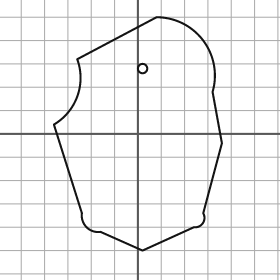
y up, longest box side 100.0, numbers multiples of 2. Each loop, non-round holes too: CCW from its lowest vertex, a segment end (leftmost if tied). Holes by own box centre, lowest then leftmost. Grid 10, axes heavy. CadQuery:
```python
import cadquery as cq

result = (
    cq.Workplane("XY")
    .moveTo(2.0, -50.0)
    .lineTo(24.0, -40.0)
    .threePointArc((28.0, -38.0), (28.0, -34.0))
    .lineTo(36.0, -4.0)
    .lineTo(32.0, 18.0)
    .threePointArc((28.0, 40.0), (8.0, 50.0))
    .lineTo(-26.0, 32.0)
    .threePointArc((-26.0, 16.0), (-36.0, 4.0))
    .lineTo(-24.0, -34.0)
    .threePointArc((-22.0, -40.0), (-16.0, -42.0))
    .close()
    .moveTo(2.0, 28.0)
    .circle(2.0)
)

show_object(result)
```